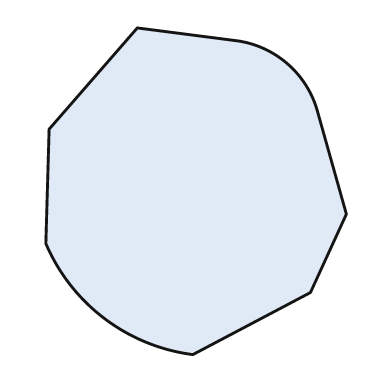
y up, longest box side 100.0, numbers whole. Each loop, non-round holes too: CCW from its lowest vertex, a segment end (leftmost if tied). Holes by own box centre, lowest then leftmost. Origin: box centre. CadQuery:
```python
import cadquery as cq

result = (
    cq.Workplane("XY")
    .moveTo(-1.0, -50.0)
    .lineTo(35.0, -31.0)
    .lineTo(46.0, -7.0)
    .lineTo(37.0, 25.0)
    .threePointArc((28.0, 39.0), (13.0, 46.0))
    .lineTo(-18.0, 50.0)
    .lineTo(-45.0, 19.0)
    .lineTo(-46.0, -16.0)
    .threePointArc((-28.0, -39.0), (-1.0, -50.0))
    .close()
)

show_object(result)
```